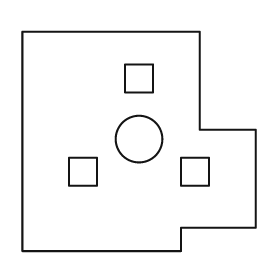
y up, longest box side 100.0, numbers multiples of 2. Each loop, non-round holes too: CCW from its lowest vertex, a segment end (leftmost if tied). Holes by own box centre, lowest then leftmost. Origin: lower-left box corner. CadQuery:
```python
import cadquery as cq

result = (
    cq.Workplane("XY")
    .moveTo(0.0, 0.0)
    .lineTo(68.0, 0.0)
    .lineTo(68.0, 10.0)
    .lineTo(100.0, 10.0)
    .lineTo(100.0, 52.0)
    .lineTo(76.0, 52.0)
    .lineTo(76.0, 94.0)
    .lineTo(0.0, 94.0)
    .close()
    .moveTo(20.0, 28.0)
    .lineTo(32.0, 28.0)
    .lineTo(32.0, 40.0)
    .lineTo(20.0, 40.0)
    .close()
    .moveTo(68.0, 28.0)
    .lineTo(80.0, 28.0)
    .lineTo(80.0, 40.0)
    .lineTo(68.0, 40.0)
    .close()
    .moveTo(50.0, 48.0)
    .circle(10.0)
    .moveTo(44.0, 68.0)
    .lineTo(56.0, 68.0)
    .lineTo(56.0, 80.0)
    .lineTo(44.0, 80.0)
    .close()
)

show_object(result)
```